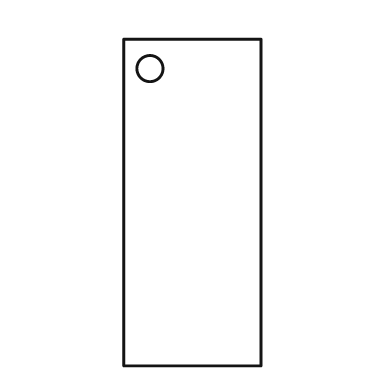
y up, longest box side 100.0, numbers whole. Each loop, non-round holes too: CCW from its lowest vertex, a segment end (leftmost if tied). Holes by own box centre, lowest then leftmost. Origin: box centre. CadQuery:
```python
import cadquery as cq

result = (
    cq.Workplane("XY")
    .moveTo(-21.0, -50.0)
    .lineTo(21.0, -50.0)
    .lineTo(21.0, 50.0)
    .lineTo(-21.0, 50.0)
    .close()
    .moveTo(-13.0, 41.0)
    .circle(4.0)
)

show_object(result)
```